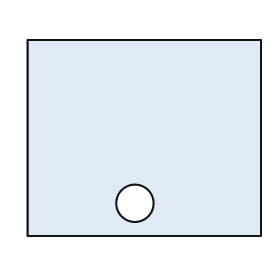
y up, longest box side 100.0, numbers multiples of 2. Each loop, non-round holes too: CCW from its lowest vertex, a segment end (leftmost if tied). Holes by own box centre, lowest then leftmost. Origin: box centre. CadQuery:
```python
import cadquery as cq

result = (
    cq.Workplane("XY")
    .moveTo(-50.0, -42.0)
    .lineTo(50.0, -42.0)
    .lineTo(50.0, 42.0)
    .lineTo(-50.0, 42.0)
    .close()
    .moveTo(-4.0, -28.0)
    .circle(8.0)
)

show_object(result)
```